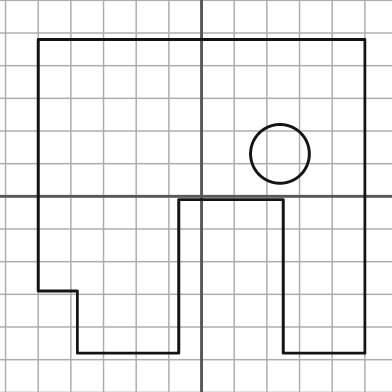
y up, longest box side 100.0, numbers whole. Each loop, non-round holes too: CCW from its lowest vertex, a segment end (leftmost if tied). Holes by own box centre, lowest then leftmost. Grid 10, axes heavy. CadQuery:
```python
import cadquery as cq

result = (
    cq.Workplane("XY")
    .moveTo(-38.0, -48.0)
    .lineTo(-7.0, -48.0)
    .lineTo(-7.0, -1.0)
    .lineTo(25.0, -1.0)
    .lineTo(25.0, -48.0)
    .lineTo(50.0, -48.0)
    .lineTo(50.0, 48.0)
    .lineTo(-50.0, 48.0)
    .lineTo(-50.0, -29.0)
    .lineTo(-38.0, -29.0)
    .close()
    .moveTo(24.0, 13.0)
    .circle(9.0)
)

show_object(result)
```